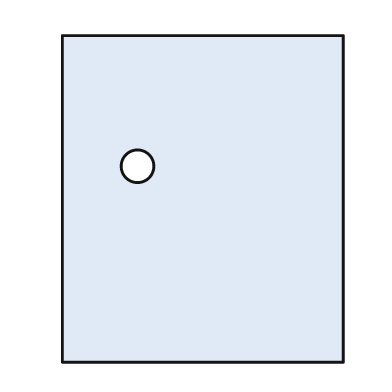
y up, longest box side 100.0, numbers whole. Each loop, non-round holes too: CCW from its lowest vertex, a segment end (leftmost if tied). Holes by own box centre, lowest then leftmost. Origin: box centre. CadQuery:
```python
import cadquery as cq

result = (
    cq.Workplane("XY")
    .moveTo(-43.0, -50.0)
    .lineTo(43.0, -50.0)
    .lineTo(43.0, 50.0)
    .lineTo(-43.0, 50.0)
    .close()
    .moveTo(-20.0, 10.0)
    .circle(5.0)
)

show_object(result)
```